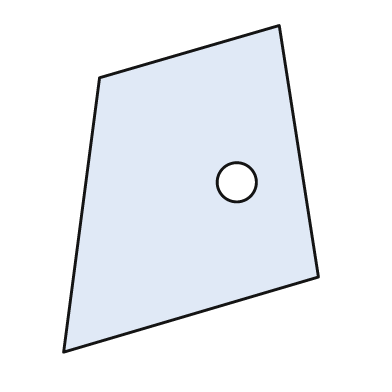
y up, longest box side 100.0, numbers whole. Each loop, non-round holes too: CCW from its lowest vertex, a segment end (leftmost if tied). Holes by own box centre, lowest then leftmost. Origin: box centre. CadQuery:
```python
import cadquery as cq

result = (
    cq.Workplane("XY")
    .moveTo(-39.0, -50.0)
    .lineTo(39.0, -27.0)
    .lineTo(27.0, 50.0)
    .lineTo(-28.0, 34.0)
    .close()
    .moveTo(14.0, 2.0)
    .circle(6.0)
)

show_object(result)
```